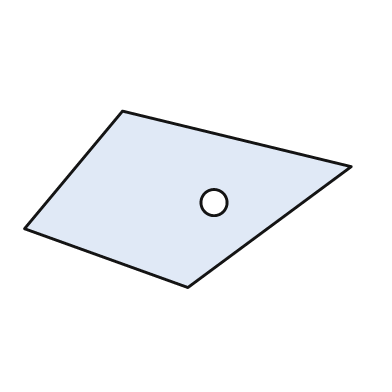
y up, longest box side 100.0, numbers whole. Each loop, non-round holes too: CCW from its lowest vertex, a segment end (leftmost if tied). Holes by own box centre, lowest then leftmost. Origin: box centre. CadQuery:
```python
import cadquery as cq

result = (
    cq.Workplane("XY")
    .moveTo(0.0, -27.0)
    .lineTo(50.0, 10.0)
    .lineTo(-20.0, 27.0)
    .lineTo(-50.0, -9.0)
    .close()
    .moveTo(8.0, -1.0)
    .circle(4.0)
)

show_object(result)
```